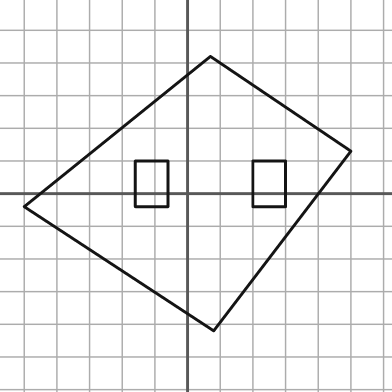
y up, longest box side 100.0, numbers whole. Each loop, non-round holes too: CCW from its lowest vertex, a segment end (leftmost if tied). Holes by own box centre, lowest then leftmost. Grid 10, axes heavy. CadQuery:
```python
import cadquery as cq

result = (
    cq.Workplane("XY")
    .moveTo(8.0, -42.0)
    .lineTo(50.0, 13.0)
    .lineTo(7.0, 42.0)
    .lineTo(-50.0, -4.0)
    .close()
    .moveTo(-16.0, -4.0)
    .lineTo(-6.0, -4.0)
    .lineTo(-6.0, 10.0)
    .lineTo(-16.0, 10.0)
    .close()
    .moveTo(20.0, -4.0)
    .lineTo(30.0, -4.0)
    .lineTo(30.0, 10.0)
    .lineTo(20.0, 10.0)
    .close()
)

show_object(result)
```